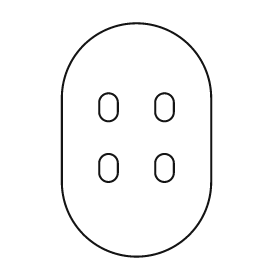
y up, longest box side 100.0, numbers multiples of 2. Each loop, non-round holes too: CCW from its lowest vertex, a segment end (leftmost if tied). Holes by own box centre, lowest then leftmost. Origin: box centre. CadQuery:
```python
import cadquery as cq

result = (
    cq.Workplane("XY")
    .moveTo(-32.0, -18.0)
    .threePointArc((0.0, -50.0), (32.0, -18.0))
    .lineTo(32.0, 18.0)
    .threePointArc((0.0, 50.0), (-32.0, 18.0))
    .close()
    .moveTo(-16.0, -14.0)
    .threePointArc((-12.0, -18.0), (-8.0, -14.0))
    .lineTo(-8.0, -10.0)
    .threePointArc((-12.0, -6.0), (-16.0, -10.0))
    .close()
    .moveTo(8.0, -14.0)
    .threePointArc((12.0, -18.0), (16.0, -14.0))
    .lineTo(16.0, -10.0)
    .threePointArc((12.0, -6.0), (8.0, -10.0))
    .close()
    .moveTo(-16.0, 12.0)
    .threePointArc((-12.0, 8.0), (-8.0, 12.0))
    .lineTo(-8.0, 16.0)
    .threePointArc((-12.0, 20.0), (-16.0, 16.0))
    .close()
    .moveTo(8.0, 12.0)
    .threePointArc((12.0, 8.0), (16.0, 12.0))
    .lineTo(16.0, 16.0)
    .threePointArc((12.0, 20.0), (8.0, 16.0))
    .close()
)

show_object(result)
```